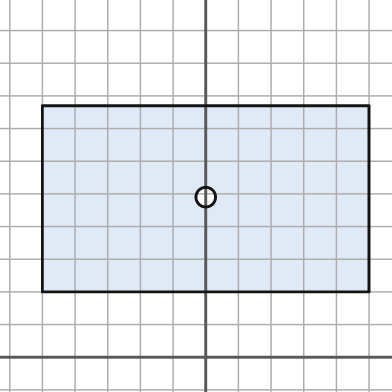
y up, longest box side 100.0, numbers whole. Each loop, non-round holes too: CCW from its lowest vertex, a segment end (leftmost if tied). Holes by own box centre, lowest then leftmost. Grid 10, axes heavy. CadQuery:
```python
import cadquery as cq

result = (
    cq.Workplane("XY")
    .moveTo(-50.0, 20.0)
    .lineTo(50.0, 20.0)
    .lineTo(50.0, 77.0)
    .lineTo(-50.0, 77.0)
    .close()
    .moveTo(0.0, 49.0)
    .circle(3.0)
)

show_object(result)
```